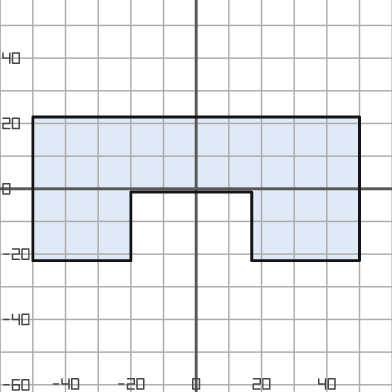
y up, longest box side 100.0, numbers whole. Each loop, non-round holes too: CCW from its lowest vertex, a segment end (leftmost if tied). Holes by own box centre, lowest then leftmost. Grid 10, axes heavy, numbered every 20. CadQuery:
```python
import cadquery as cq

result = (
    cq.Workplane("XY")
    .moveTo(-50.0, -22.0)
    .lineTo(-20.0, -22.0)
    .lineTo(-20.0, -1.0)
    .lineTo(17.0, -1.0)
    .lineTo(17.0, -22.0)
    .lineTo(50.0, -22.0)
    .lineTo(50.0, 22.0)
    .lineTo(-50.0, 22.0)
    .close()
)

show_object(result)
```